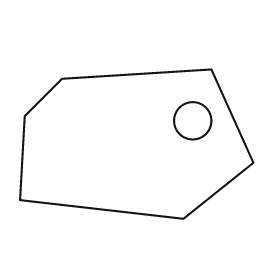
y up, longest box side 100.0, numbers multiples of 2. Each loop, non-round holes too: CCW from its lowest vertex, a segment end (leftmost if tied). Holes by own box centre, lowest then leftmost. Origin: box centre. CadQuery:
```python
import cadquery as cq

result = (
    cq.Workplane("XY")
    .moveTo(20.0, -32.0)
    .lineTo(50.0, -8.0)
    .lineTo(32.0, 32.0)
    .lineTo(-32.0, 28.0)
    .lineTo(-48.0, 12.0)
    .lineTo(-50.0, -24.0)
    .close()
    .moveTo(24.0, 10.0)
    .circle(8.0)
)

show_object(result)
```